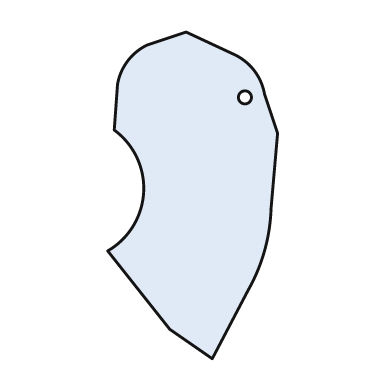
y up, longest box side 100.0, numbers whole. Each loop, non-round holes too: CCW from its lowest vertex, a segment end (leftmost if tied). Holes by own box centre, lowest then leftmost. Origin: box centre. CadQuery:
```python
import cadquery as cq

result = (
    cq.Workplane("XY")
    .moveTo(6.0, -50.0)
    .lineTo(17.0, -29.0)
    .threePointArc((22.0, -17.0), (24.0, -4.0))
    .lineTo(26.0, 19.0)
    .lineTo(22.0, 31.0)
    .threePointArc((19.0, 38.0), (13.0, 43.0))
    .lineTo(-2.0, 50.0)
    .lineTo(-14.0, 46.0)
    .threePointArc((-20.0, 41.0), (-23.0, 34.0))
    .lineTo(-24.0, 20.0)
    .threePointArc((-15.0, 1.0), (-26.0, -17.0))
    .lineTo(-7.0, -41.0)
    .close()
    .moveTo(16.0, 30.0)
    .circle(2.0)
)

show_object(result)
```